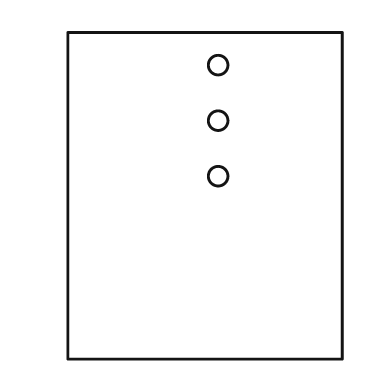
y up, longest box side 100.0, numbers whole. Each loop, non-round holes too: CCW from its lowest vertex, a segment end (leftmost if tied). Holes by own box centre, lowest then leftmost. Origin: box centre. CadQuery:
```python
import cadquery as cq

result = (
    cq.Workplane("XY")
    .moveTo(-42.0, -50.0)
    .lineTo(42.0, -50.0)
    .lineTo(42.0, 50.0)
    .lineTo(-42.0, 50.0)
    .close()
    .moveTo(4.0, 6.0)
    .circle(3.0)
    .moveTo(4.0, 23.0)
    .circle(3.0)
    .moveTo(4.0, 40.0)
    .circle(3.0)
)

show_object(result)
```